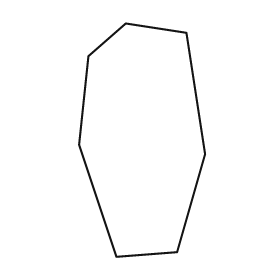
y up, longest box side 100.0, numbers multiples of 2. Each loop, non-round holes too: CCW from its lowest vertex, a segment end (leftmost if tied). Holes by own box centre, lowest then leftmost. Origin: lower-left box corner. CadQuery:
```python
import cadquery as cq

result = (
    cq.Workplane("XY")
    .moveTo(16.0, 0.0)
    .lineTo(42.0, 2.0)
    .lineTo(54.0, 44.0)
    .lineTo(46.0, 96.0)
    .lineTo(20.0, 100.0)
    .lineTo(4.0, 86.0)
    .lineTo(0.0, 48.0)
    .close()
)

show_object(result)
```